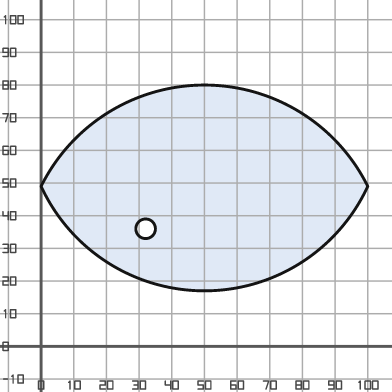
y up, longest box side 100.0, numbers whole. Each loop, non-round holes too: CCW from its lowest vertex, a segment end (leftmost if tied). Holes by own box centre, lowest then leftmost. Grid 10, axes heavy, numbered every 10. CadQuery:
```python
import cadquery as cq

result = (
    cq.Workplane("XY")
    .moveTo(0.0, 49.0)
    .threePointArc((50.0, 17.0), (100.0, 49.0))
    .threePointArc((50.0, 80.0), (0.0, 49.0))
    .close()
    .moveTo(32.0, 36.0)
    .circle(3.0)
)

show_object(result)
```